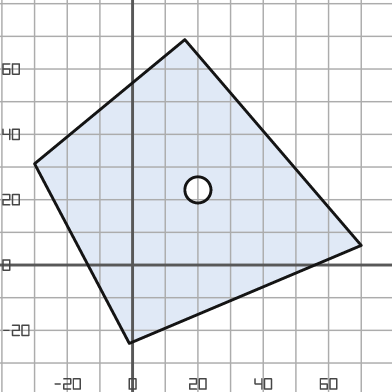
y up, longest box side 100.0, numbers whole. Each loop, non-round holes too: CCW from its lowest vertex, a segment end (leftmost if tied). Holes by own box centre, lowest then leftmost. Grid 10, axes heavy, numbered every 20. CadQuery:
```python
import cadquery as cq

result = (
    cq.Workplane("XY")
    .moveTo(-1.0, -24.0)
    .lineTo(70.0, 6.0)
    .lineTo(16.0, 69.0)
    .lineTo(-30.0, 31.0)
    .close()
    .moveTo(20.0, 23.0)
    .circle(4.0)
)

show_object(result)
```